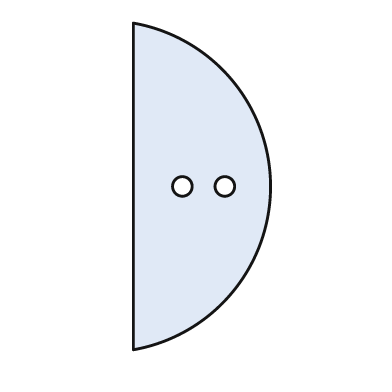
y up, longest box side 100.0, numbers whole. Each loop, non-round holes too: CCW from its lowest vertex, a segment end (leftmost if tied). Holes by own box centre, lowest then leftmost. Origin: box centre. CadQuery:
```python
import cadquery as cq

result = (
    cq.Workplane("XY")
    .moveTo(-21.0, -50.0)
    .threePointArc((21.0, 0.0), (-21.0, 50.0))
    .close()
    .moveTo(-6.0, 0.0)
    .circle(3.0)
    .moveTo(7.0, 0.0)
    .circle(3.0)
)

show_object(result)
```